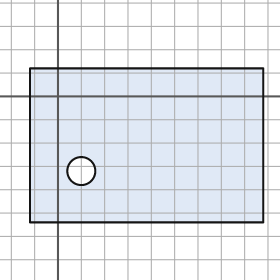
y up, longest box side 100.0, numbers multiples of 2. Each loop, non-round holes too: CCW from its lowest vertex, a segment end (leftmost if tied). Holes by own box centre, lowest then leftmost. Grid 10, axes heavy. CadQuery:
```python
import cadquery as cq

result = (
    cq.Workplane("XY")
    .moveTo(-12.0, -54.0)
    .lineTo(88.0, -54.0)
    .lineTo(88.0, 12.0)
    .lineTo(-12.0, 12.0)
    .close()
    .moveTo(10.0, -32.0)
    .circle(6.0)
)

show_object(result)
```